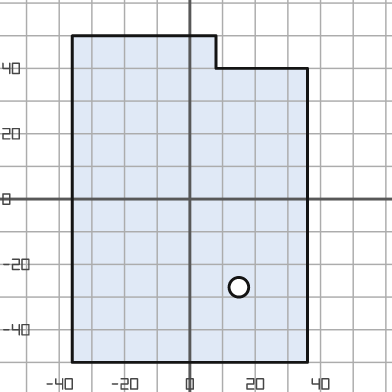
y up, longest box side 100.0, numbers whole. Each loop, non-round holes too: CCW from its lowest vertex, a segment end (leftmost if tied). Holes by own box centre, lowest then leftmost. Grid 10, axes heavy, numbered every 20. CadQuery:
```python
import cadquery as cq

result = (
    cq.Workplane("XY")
    .moveTo(-36.0, -50.0)
    .lineTo(36.0, -50.0)
    .lineTo(36.0, 40.0)
    .lineTo(8.0, 40.0)
    .lineTo(8.0, 50.0)
    .lineTo(-36.0, 50.0)
    .close()
    .moveTo(15.0, -27.0)
    .circle(3.0)
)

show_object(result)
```